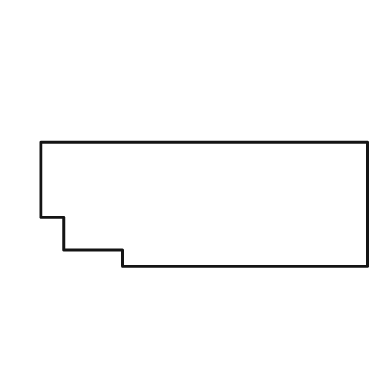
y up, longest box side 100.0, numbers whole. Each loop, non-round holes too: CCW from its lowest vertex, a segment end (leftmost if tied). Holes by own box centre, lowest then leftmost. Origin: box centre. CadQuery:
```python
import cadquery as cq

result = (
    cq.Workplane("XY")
    .moveTo(-25.0, -19.0)
    .lineTo(50.0, -19.0)
    .lineTo(50.0, 19.0)
    .lineTo(-50.0, 19.0)
    .lineTo(-50.0, -4.0)
    .lineTo(-43.0, -4.0)
    .lineTo(-43.0, -14.0)
    .lineTo(-25.0, -14.0)
    .close()
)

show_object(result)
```